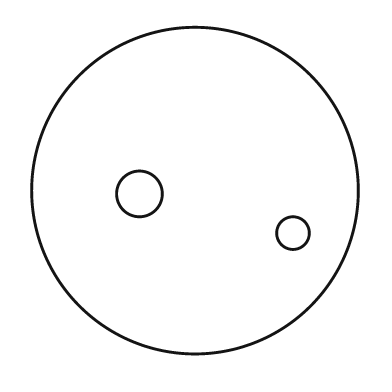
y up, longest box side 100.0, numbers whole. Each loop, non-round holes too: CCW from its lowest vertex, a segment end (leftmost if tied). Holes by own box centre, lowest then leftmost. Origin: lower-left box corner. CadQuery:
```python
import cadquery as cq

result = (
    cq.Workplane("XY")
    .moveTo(50.0, 50.0)
    .circle(50.0)
    .moveTo(80.0, 37.0)
    .circle(5.0)
    .moveTo(33.0, 49.0)
    .circle(7.0)
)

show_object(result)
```